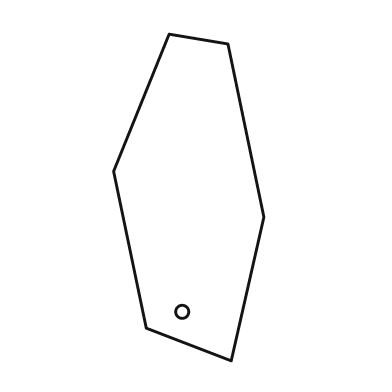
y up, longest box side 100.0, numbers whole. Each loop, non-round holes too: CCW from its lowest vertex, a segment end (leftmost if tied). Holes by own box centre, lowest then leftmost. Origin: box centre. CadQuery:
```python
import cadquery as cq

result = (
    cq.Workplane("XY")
    .moveTo(13.0, -50.0)
    .lineTo(23.0, -6.0)
    .lineTo(12.0, 47.0)
    .lineTo(-6.0, 50.0)
    .lineTo(-23.0, 8.0)
    .lineTo(-13.0, -40.0)
    .close()
    .moveTo(-2.0, -35.0)
    .circle(2.0)
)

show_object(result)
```